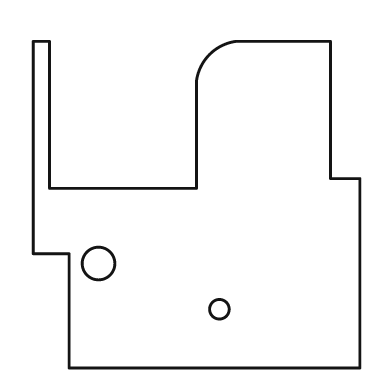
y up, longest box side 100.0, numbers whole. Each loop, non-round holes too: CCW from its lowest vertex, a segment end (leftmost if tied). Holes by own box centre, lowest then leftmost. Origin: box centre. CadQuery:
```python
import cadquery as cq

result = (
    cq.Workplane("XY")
    .moveTo(-39.0, -50.0)
    .lineTo(50.0, -50.0)
    .lineTo(50.0, 8.0)
    .lineTo(41.0, 8.0)
    .lineTo(41.0, 50.0)
    .lineTo(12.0, 50.0)
    .threePointArc((4.0, 46.0), (0.0, 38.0))
    .lineTo(0.0, 5.0)
    .lineTo(-45.0, 5.0)
    .lineTo(-45.0, 50.0)
    .lineTo(-50.0, 50.0)
    .lineTo(-50.0, -15.0)
    .lineTo(-39.0, -15.0)
    .close()
    .moveTo(7.0, -32.0)
    .circle(3.0)
    .moveTo(-30.0, -18.0)
    .circle(5.0)
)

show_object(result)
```